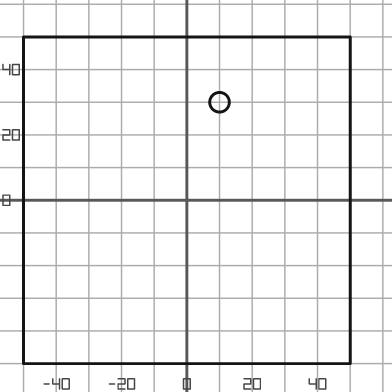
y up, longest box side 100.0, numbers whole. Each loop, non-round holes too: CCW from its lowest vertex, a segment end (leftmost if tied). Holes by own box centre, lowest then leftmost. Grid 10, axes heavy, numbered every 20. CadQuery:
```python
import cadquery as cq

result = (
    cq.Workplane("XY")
    .moveTo(-50.0, -50.0)
    .lineTo(50.0, -50.0)
    .lineTo(50.0, 50.0)
    .lineTo(-50.0, 50.0)
    .close()
    .moveTo(10.0, 30.0)
    .circle(3.0)
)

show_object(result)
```